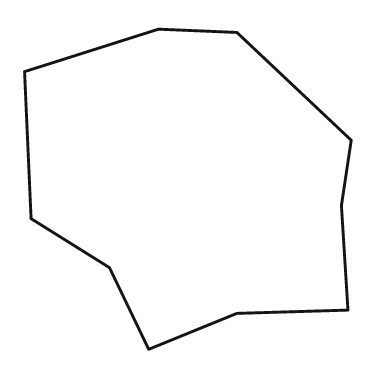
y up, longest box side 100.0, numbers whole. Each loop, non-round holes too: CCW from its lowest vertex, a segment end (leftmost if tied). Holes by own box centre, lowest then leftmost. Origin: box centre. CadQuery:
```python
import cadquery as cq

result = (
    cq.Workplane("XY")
    .moveTo(-12.0, -49.0)
    .lineTo(15.0, -38.0)
    .lineTo(49.0, -37.0)
    .lineTo(47.0, -5.0)
    .lineTo(50.0, 15.0)
    .lineTo(15.0, 48.0)
    .lineTo(-9.0, 49.0)
    .lineTo(-50.0, 36.0)
    .lineTo(-48.0, -9.0)
    .lineTo(-24.0, -24.0)
    .close()
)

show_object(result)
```